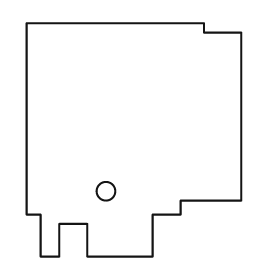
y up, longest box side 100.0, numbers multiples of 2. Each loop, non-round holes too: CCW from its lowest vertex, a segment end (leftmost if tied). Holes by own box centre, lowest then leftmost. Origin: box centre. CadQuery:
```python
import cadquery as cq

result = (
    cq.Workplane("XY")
    .moveTo(-40.0, -50.0)
    .lineTo(-32.0, -50.0)
    .lineTo(-32.0, -36.0)
    .lineTo(-20.0, -36.0)
    .lineTo(-20.0, -50.0)
    .lineTo(8.0, -50.0)
    .lineTo(8.0, -32.0)
    .lineTo(20.0, -32.0)
    .lineTo(20.0, -26.0)
    .lineTo(46.0, -26.0)
    .lineTo(46.0, 46.0)
    .lineTo(30.0, 46.0)
    .lineTo(30.0, 50.0)
    .lineTo(-46.0, 50.0)
    .lineTo(-46.0, -32.0)
    .lineTo(-40.0, -32.0)
    .close()
    .moveTo(-12.0, -22.0)
    .circle(4.0)
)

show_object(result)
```